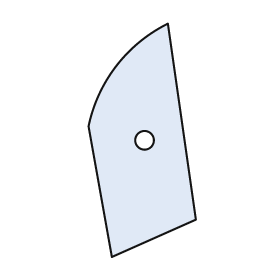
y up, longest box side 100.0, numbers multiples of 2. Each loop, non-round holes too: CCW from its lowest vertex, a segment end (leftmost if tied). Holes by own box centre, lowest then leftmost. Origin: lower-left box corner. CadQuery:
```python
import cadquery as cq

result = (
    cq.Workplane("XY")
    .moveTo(10.0, 0.0)
    .lineTo(46.0, 16.0)
    .lineTo(34.0, 100.0)
    .threePointArc((12.0, 82.0), (0.0, 56.0))
    .close()
    .moveTo(24.0, 50.0)
    .circle(4.0)
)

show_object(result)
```